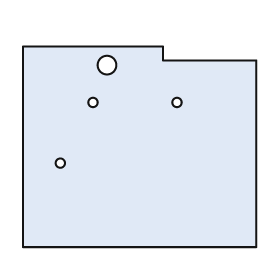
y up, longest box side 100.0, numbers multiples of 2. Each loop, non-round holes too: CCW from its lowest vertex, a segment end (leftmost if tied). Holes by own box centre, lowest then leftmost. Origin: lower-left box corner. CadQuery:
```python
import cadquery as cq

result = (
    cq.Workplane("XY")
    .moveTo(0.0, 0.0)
    .lineTo(100.0, 0.0)
    .lineTo(100.0, 80.0)
    .lineTo(60.0, 80.0)
    .lineTo(60.0, 86.0)
    .lineTo(0.0, 86.0)
    .close()
    .moveTo(16.0, 36.0)
    .circle(2.0)
    .moveTo(30.0, 62.0)
    .circle(2.0)
    .moveTo(66.0, 62.0)
    .circle(2.0)
    .moveTo(36.0, 78.0)
    .circle(4.0)
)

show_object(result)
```